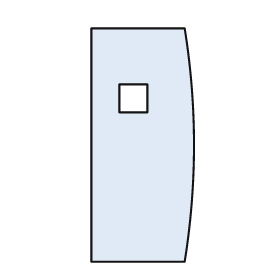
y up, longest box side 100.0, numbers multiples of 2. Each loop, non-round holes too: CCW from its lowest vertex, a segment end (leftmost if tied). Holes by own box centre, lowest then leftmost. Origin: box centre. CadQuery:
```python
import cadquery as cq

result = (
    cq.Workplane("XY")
    .moveTo(-22.0, -50.0)
    .lineTo(18.0, -50.0)
    .threePointArc((22.0, 0.0), (18.0, 50.0))
    .lineTo(-22.0, 50.0)
    .close()
    .moveTo(-10.0, 14.0)
    .lineTo(2.0, 14.0)
    .lineTo(2.0, 26.0)
    .lineTo(-10.0, 26.0)
    .close()
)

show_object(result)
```